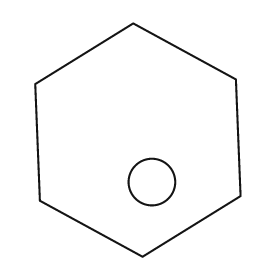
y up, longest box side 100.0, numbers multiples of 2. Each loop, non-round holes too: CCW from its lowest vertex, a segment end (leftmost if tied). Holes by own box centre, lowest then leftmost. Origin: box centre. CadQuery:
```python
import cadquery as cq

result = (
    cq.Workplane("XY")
    .moveTo(2.0, -50.0)
    .lineTo(44.0, -24.0)
    .lineTo(42.0, 26.0)
    .lineTo(-2.0, 50.0)
    .lineTo(-44.0, 24.0)
    .lineTo(-42.0, -26.0)
    .close()
    .moveTo(6.0, -18.0)
    .circle(10.0)
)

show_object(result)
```